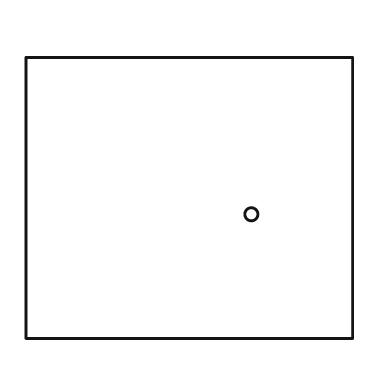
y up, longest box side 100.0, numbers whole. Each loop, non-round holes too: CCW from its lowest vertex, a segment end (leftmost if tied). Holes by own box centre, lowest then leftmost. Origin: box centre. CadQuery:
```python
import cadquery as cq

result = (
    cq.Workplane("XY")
    .moveTo(-50.0, -43.0)
    .lineTo(50.0, -43.0)
    .lineTo(50.0, 43.0)
    .lineTo(-50.0, 43.0)
    .close()
    .moveTo(19.0, -5.0)
    .circle(2.0)
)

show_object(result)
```